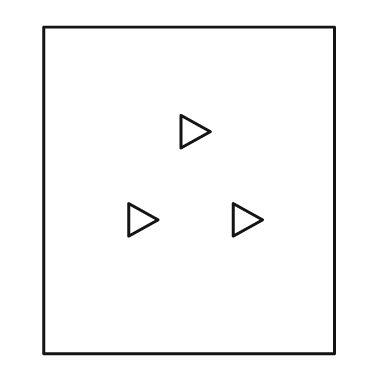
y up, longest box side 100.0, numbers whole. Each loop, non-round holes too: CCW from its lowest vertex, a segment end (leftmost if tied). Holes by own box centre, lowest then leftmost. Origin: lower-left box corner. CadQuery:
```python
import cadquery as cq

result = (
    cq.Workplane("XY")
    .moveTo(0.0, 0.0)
    .lineTo(89.0, 0.0)
    .lineTo(89.0, 100.0)
    .lineTo(0.0, 100.0)
    .close()
    .moveTo(26.0, 36.0)
    .lineTo(35.0, 41.0)
    .lineTo(26.0, 46.0)
    .close()
    .moveTo(58.0, 36.0)
    .lineTo(67.0, 41.0)
    .lineTo(58.0, 46.0)
    .close()
    .moveTo(42.0, 63.0)
    .lineTo(51.0, 68.0)
    .lineTo(42.0, 73.0)
    .close()
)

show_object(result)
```